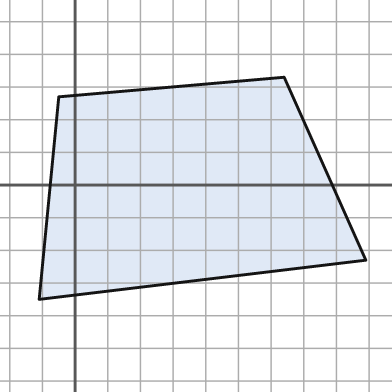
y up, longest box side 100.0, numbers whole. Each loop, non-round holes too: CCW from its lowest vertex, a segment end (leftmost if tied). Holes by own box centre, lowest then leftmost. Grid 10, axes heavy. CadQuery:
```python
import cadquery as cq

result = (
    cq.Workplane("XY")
    .moveTo(-11.0, -35.0)
    .lineTo(89.0, -23.0)
    .lineTo(64.0, 33.0)
    .lineTo(-5.0, 27.0)
    .close()
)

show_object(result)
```